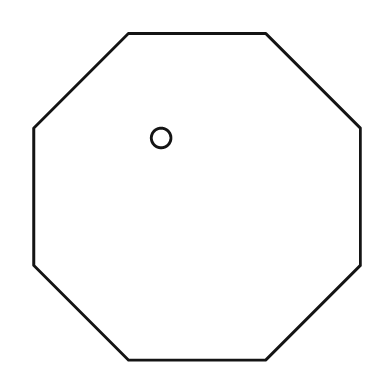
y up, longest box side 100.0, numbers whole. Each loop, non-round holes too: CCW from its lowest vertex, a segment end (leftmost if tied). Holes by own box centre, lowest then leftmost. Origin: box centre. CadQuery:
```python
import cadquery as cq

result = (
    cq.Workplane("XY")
    .moveTo(-21.0, -50.0)
    .lineTo(21.0, -50.0)
    .lineTo(50.0, -21.0)
    .lineTo(50.0, 21.0)
    .lineTo(21.0, 50.0)
    .lineTo(-21.0, 50.0)
    .lineTo(-50.0, 21.0)
    .lineTo(-50.0, -21.0)
    .close()
    .moveTo(-11.0, 18.0)
    .circle(3.0)
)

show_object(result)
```